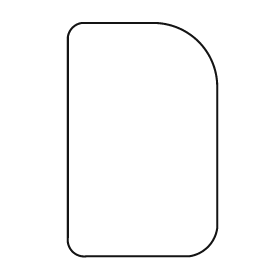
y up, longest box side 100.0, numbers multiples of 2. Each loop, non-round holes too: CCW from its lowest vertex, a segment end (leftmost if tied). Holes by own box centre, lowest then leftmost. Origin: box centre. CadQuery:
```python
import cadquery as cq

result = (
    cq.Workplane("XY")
    .moveTo(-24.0, -50.0)
    .lineTo(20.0, -50.0)
    .threePointArc((28.0, -46.0), (32.0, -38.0))
    .lineTo(32.0, 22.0)
    .threePointArc((24.0, 42.0), (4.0, 50.0))
    .lineTo(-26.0, 50.0)
    .threePointArc((-30.0, 48.0), (-32.0, 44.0))
    .lineTo(-32.0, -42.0)
    .threePointArc((-30.0, -48.0), (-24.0, -50.0))
    .close()
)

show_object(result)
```